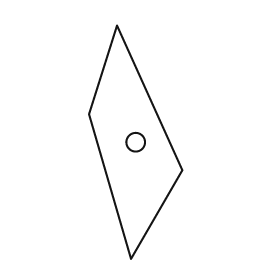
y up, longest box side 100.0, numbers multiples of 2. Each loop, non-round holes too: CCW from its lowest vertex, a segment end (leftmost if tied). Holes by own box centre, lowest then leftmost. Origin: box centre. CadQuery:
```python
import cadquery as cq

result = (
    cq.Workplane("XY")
    .moveTo(-2.0, -50.0)
    .lineTo(20.0, -12.0)
    .lineTo(-8.0, 50.0)
    .lineTo(-20.0, 12.0)
    .close()
    .moveTo(0.0, 0.0)
    .circle(4.0)
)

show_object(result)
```